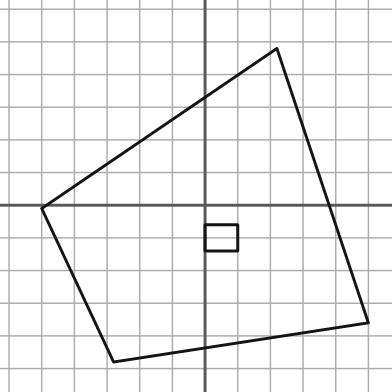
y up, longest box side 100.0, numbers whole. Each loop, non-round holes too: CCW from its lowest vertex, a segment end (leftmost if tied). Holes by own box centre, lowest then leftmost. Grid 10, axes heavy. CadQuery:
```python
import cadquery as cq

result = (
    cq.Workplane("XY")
    .moveTo(-28.0, -48.0)
    .lineTo(50.0, -36.0)
    .lineTo(22.0, 48.0)
    .lineTo(-50.0, -1.0)
    .close()
    .moveTo(0.0, -14.0)
    .lineTo(10.0, -14.0)
    .lineTo(10.0, -6.0)
    .lineTo(0.0, -6.0)
    .close()
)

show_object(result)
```